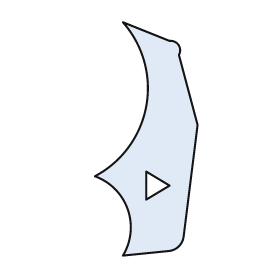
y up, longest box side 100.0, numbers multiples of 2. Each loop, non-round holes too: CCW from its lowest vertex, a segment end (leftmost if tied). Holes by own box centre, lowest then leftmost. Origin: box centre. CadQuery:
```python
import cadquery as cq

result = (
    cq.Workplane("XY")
    .moveTo(-10.0, -50.0)
    .lineTo(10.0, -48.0)
    .threePointArc((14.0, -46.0), (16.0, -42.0))
    .lineTo(22.0, 6.0)
    .lineTo(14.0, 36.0)
    .threePointArc((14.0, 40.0), (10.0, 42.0))
    .lineTo(-10.0, 50.0)
    .threePointArc((0.0, 14.0), (-22.0, -16.0))
    .threePointArc((-8.0, -30.0), (-10.0, -50.0))
    .close()
    .moveTo(0.0, -26.0)
    .lineTo(10.0, -20.0)
    .lineTo(0.0, -14.0)
    .close()
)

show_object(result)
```